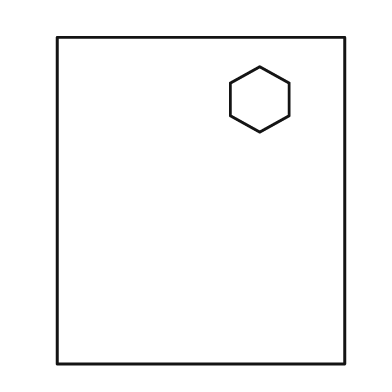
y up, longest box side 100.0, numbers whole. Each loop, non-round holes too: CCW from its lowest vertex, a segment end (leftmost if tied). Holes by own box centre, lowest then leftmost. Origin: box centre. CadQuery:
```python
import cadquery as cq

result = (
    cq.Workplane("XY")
    .moveTo(-44.0, -50.0)
    .lineTo(44.0, -50.0)
    .lineTo(44.0, 50.0)
    .lineTo(-44.0, 50.0)
    .close()
    .moveTo(18.0, 21.0)
    .lineTo(27.0, 26.0)
    .lineTo(27.0, 36.0)
    .lineTo(18.0, 41.0)
    .lineTo(9.0, 36.0)
    .lineTo(9.0, 26.0)
    .close()
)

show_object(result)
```